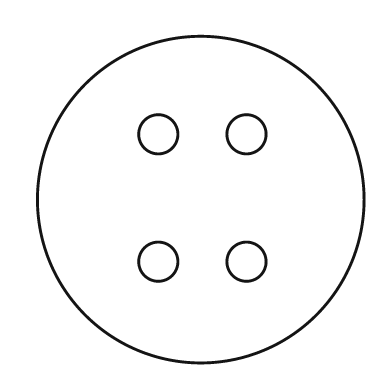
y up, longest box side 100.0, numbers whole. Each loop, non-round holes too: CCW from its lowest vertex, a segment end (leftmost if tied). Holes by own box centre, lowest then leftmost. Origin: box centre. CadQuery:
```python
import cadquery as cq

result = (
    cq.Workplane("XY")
    .moveTo(0.0, 0.0)
    .circle(50.0)
    .moveTo(-13.0, -19.0)
    .circle(6.0)
    .moveTo(14.0, -19.0)
    .circle(6.0)
    .moveTo(-13.0, 20.0)
    .circle(6.0)
    .moveTo(14.0, 20.0)
    .circle(6.0)
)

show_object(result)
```